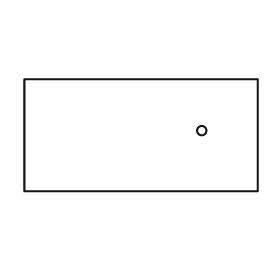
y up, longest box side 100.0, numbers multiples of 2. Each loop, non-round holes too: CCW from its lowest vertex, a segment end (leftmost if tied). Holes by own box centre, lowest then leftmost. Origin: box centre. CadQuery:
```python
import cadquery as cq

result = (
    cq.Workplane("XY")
    .moveTo(-50.0, -24.0)
    .lineTo(50.0, -24.0)
    .lineTo(50.0, 24.0)
    .lineTo(-50.0, 24.0)
    .close()
    .moveTo(26.0, 2.0)
    .circle(2.0)
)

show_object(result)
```